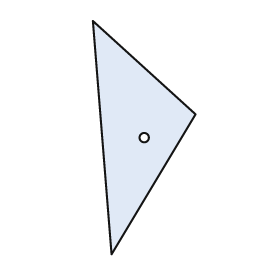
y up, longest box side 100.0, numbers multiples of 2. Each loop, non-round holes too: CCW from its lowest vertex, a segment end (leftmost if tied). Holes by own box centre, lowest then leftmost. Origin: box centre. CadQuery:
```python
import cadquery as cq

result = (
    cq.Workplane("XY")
    .moveTo(-14.0, -50.0)
    .lineTo(22.0, 10.0)
    .lineTo(-22.0, 50.0)
    .close()
    .moveTo(0.0, 0.0)
    .circle(2.0)
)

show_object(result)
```